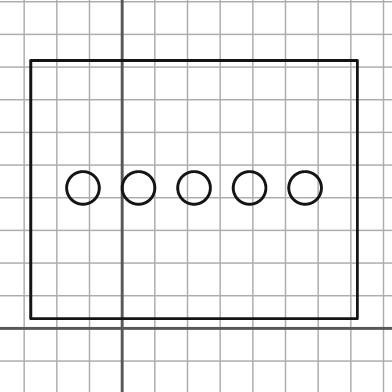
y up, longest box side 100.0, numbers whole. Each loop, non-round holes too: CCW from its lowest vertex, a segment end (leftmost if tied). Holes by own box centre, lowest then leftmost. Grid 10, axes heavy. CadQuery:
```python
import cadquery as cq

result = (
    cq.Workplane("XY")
    .moveTo(-28.0, 3.0)
    .lineTo(72.0, 3.0)
    .lineTo(72.0, 82.0)
    .lineTo(-28.0, 82.0)
    .close()
    .moveTo(-12.0, 43.0)
    .circle(5.0)
    .moveTo(5.0, 43.0)
    .circle(5.0)
    .moveTo(22.0, 43.0)
    .circle(5.0)
    .moveTo(39.0, 43.0)
    .circle(5.0)
    .moveTo(56.0, 43.0)
    .circle(5.0)
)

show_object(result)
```